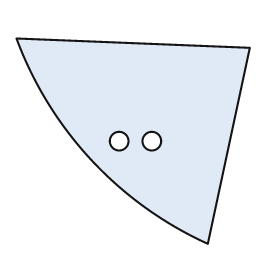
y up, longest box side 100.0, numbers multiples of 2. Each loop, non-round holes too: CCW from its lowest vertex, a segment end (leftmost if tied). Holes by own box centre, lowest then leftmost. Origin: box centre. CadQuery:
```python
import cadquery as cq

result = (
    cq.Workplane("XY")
    .moveTo(32.0, -44.0)
    .lineTo(50.0, 40.0)
    .lineTo(-50.0, 44.0)
    .threePointArc((-18.0, -8.0), (32.0, -44.0))
    .close()
    .moveTo(-6.0, 0.0)
    .circle(4.0)
    .moveTo(8.0, 0.0)
    .circle(4.0)
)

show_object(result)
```